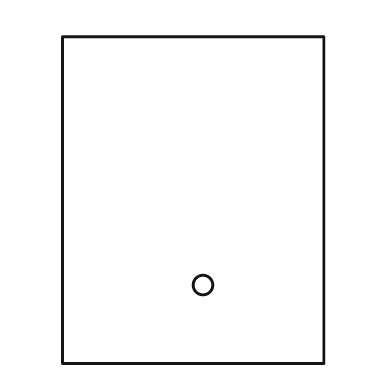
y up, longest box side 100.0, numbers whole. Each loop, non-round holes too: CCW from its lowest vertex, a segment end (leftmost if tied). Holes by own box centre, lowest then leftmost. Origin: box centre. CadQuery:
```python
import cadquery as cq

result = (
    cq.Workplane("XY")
    .moveTo(-40.0, -50.0)
    .lineTo(40.0, -50.0)
    .lineTo(40.0, 50.0)
    .lineTo(-40.0, 50.0)
    .close()
    .moveTo(3.0, -26.0)
    .circle(3.0)
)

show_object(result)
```